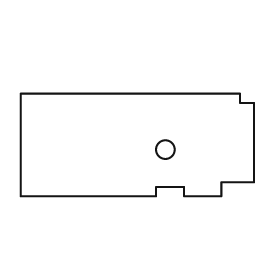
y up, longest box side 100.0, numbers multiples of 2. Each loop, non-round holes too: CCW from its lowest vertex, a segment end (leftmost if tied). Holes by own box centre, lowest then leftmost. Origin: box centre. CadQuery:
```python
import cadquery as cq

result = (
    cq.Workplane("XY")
    .moveTo(-50.0, -22.0)
    .lineTo(8.0, -22.0)
    .lineTo(8.0, -18.0)
    .lineTo(20.0, -18.0)
    .lineTo(20.0, -22.0)
    .lineTo(36.0, -22.0)
    .lineTo(36.0, -16.0)
    .lineTo(50.0, -16.0)
    .lineTo(50.0, 18.0)
    .lineTo(44.0, 18.0)
    .lineTo(44.0, 22.0)
    .lineTo(-50.0, 22.0)
    .close()
    .moveTo(12.0, -2.0)
    .circle(4.0)
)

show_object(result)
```